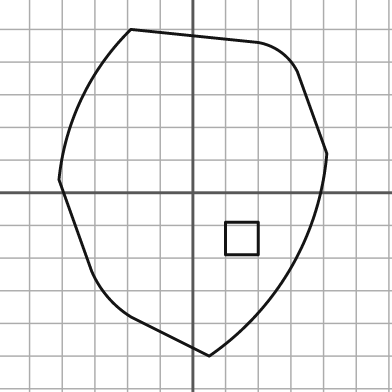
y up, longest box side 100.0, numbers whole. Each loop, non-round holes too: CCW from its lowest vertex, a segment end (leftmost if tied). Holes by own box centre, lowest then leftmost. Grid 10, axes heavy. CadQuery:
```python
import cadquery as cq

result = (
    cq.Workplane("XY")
    .moveTo(5.0, -50.0)
    .threePointArc((30.0, -23.0), (41.0, 12.0))
    .lineTo(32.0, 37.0)
    .threePointArc((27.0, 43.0), (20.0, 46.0))
    .lineTo(-19.0, 50.0)
    .threePointArc((-34.0, 29.0), (-41.0, 4.0))
    .lineTo(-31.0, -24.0)
    .threePointArc((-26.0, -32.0), (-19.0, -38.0))
    .close()
    .moveTo(10.0, -19.0)
    .lineTo(20.0, -19.0)
    .lineTo(20.0, -9.0)
    .lineTo(10.0, -9.0)
    .close()
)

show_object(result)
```